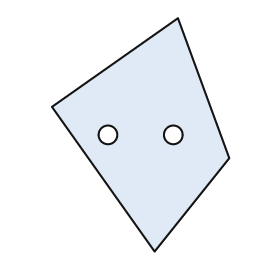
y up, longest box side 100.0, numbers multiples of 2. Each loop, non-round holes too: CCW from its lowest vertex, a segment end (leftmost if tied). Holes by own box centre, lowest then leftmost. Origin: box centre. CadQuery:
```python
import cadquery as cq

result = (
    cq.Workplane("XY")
    .moveTo(6.0, -50.0)
    .lineTo(38.0, -10.0)
    .lineTo(16.0, 50.0)
    .lineTo(-38.0, 12.0)
    .close()
    .moveTo(-14.0, 0.0)
    .circle(4.0)
    .moveTo(14.0, 0.0)
    .circle(4.0)
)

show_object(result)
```